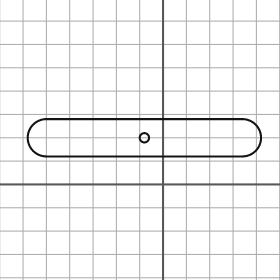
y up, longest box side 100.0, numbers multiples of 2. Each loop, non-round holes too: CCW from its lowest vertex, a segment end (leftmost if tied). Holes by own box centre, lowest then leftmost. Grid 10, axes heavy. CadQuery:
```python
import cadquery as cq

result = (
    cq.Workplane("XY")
    .moveTo(-50.0, 12.0)
    .lineTo(34.0, 12.0)
    .threePointArc((42.0, 20.0), (34.0, 28.0))
    .lineTo(-50.0, 28.0)
    .threePointArc((-58.0, 20.0), (-50.0, 12.0))
    .close()
    .moveTo(-8.0, 20.0)
    .circle(2.0)
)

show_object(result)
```